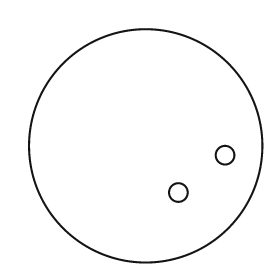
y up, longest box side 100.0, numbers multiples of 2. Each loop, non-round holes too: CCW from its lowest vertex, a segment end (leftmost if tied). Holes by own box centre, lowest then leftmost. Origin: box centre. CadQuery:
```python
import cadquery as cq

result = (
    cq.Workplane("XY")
    .moveTo(0.0, 0.0)
    .circle(50.0)
    .moveTo(14.0, -20.0)
    .circle(4.0)
    .moveTo(34.0, -4.0)
    .circle(4.0)
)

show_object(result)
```